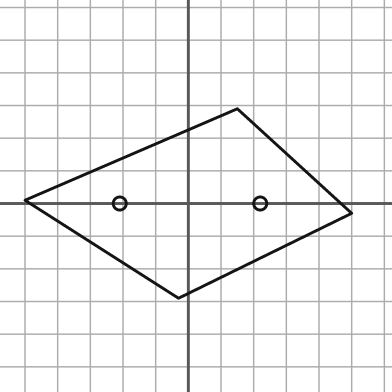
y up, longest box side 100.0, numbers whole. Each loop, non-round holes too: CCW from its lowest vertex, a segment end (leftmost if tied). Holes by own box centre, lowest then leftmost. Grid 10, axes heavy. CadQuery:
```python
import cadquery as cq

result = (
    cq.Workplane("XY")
    .moveTo(-3.0, -29.0)
    .lineTo(50.0, -3.0)
    .lineTo(15.0, 29.0)
    .lineTo(-50.0, 1.0)
    .close()
    .moveTo(-21.0, 0.0)
    .circle(2.0)
    .moveTo(22.0, 0.0)
    .circle(2.0)
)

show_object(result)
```